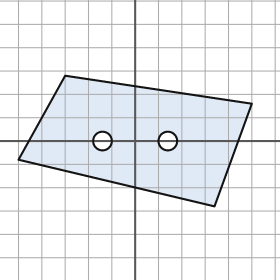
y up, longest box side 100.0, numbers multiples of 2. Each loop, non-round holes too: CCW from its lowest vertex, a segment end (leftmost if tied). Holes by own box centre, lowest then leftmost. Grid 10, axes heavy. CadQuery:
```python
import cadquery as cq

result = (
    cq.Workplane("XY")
    .moveTo(34.0, -28.0)
    .lineTo(50.0, 16.0)
    .lineTo(-30.0, 28.0)
    .lineTo(-50.0, -8.0)
    .close()
    .moveTo(-14.0, 0.0)
    .circle(4.0)
    .moveTo(14.0, 0.0)
    .circle(4.0)
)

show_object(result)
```